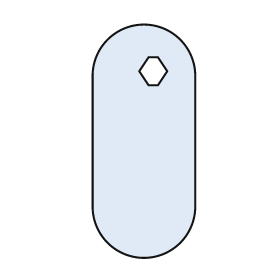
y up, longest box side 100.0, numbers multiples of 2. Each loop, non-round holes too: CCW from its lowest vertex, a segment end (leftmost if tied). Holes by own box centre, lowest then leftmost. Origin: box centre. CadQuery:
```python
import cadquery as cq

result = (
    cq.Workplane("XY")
    .moveTo(-22.0, -28.0)
    .threePointArc((0.0, -50.0), (22.0, -28.0))
    .lineTo(22.0, 28.0)
    .threePointArc((0.0, 50.0), (-22.0, 28.0))
    .close()
    .moveTo(2.0, 24.0)
    .lineTo(6.0, 24.0)
    .lineTo(10.0, 30.0)
    .lineTo(6.0, 36.0)
    .lineTo(2.0, 36.0)
    .lineTo(-2.0, 30.0)
    .close()
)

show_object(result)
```